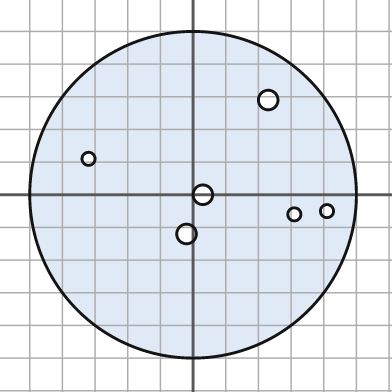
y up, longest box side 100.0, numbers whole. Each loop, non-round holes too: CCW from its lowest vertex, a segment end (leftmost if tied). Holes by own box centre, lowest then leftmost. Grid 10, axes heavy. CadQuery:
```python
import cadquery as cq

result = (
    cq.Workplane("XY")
    .moveTo(0.0, 0.0)
    .circle(50.0)
    .moveTo(-2.0, -12.0)
    .circle(3.0)
    .moveTo(31.0, -6.0)
    .circle(2.0)
    .moveTo(41.0, -5.0)
    .circle(2.0)
    .moveTo(3.0, 0.0)
    .circle(3.0)
    .moveTo(-32.0, 11.0)
    .circle(2.0)
    .moveTo(23.0, 29.0)
    .circle(3.0)
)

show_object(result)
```